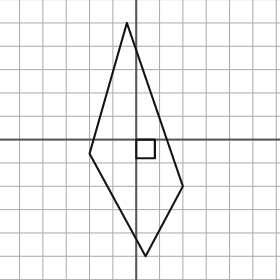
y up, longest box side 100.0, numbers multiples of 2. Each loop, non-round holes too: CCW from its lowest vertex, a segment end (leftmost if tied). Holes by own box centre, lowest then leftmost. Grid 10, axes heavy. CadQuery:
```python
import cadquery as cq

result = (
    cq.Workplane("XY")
    .moveTo(4.0, -50.0)
    .lineTo(20.0, -20.0)
    .lineTo(-4.0, 50.0)
    .lineTo(-20.0, -6.0)
    .close()
    .moveTo(0.0, -8.0)
    .lineTo(8.0, -8.0)
    .lineTo(8.0, 0.0)
    .lineTo(0.0, 0.0)
    .close()
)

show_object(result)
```